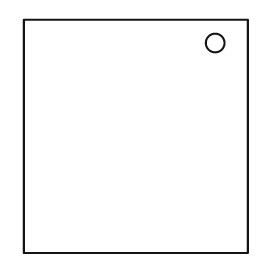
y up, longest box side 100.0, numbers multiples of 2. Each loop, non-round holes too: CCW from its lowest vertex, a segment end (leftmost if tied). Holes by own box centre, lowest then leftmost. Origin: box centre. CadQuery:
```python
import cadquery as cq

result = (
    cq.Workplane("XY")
    .moveTo(-48.0, -50.0)
    .lineTo(48.0, -50.0)
    .lineTo(48.0, 50.0)
    .lineTo(-48.0, 50.0)
    .close()
    .moveTo(34.0, 40.0)
    .circle(4.0)
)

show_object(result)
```